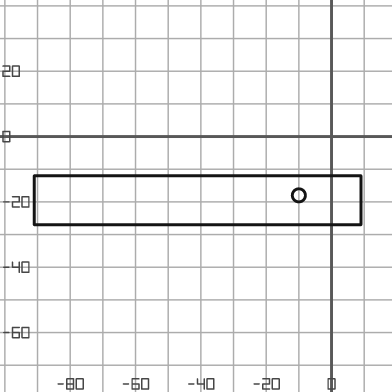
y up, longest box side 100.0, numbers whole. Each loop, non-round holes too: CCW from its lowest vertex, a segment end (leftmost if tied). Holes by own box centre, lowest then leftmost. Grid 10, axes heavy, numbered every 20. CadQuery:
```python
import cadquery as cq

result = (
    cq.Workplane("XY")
    .moveTo(-91.0, -27.0)
    .lineTo(9.0, -27.0)
    .lineTo(9.0, -12.0)
    .lineTo(-91.0, -12.0)
    .close()
    .moveTo(-10.0, -18.0)
    .circle(2.0)
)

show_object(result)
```